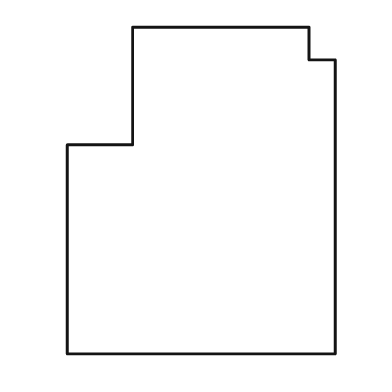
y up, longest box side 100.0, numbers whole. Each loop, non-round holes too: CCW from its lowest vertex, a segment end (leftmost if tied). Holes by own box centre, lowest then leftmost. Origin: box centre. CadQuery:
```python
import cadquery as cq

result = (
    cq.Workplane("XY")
    .moveTo(-41.0, -50.0)
    .lineTo(41.0, -50.0)
    .lineTo(41.0, 40.0)
    .lineTo(33.0, 40.0)
    .lineTo(33.0, 50.0)
    .lineTo(-21.0, 50.0)
    .lineTo(-21.0, 14.0)
    .lineTo(-41.0, 14.0)
    .close()
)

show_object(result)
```